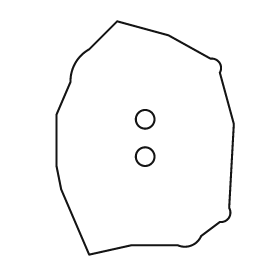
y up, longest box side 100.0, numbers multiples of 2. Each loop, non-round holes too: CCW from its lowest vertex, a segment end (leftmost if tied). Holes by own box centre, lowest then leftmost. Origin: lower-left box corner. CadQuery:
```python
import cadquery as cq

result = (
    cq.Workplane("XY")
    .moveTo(14.0, 0.0)
    .lineTo(32.0, 4.0)
    .lineTo(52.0, 4.0)
    .threePointArc((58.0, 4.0), (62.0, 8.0))
    .lineTo(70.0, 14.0)
    .threePointArc((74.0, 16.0), (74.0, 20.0))
    .lineTo(76.0, 56.0)
    .lineTo(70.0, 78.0)
    .threePointArc((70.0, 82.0), (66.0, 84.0))
    .lineTo(48.0, 94.0)
    .lineTo(26.0, 100.0)
    .lineTo(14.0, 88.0)
    .threePointArc((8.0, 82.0), (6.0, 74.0))
    .lineTo(0.0, 60.0)
    .lineTo(0.0, 38.0)
    .lineTo(2.0, 28.0)
    .close()
    .moveTo(38.0, 42.0)
    .circle(4.0)
    .moveTo(38.0, 58.0)
    .circle(4.0)
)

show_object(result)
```